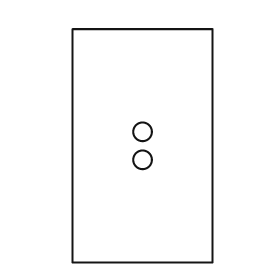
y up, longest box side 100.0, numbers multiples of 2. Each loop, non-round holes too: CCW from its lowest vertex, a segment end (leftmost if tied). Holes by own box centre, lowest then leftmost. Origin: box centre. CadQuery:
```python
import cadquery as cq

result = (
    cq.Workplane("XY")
    .moveTo(-30.0, -50.0)
    .lineTo(30.0, -50.0)
    .lineTo(30.0, 50.0)
    .lineTo(-30.0, 50.0)
    .close()
    .moveTo(0.0, -6.0)
    .circle(4.0)
    .moveTo(0.0, 6.0)
    .circle(4.0)
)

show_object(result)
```